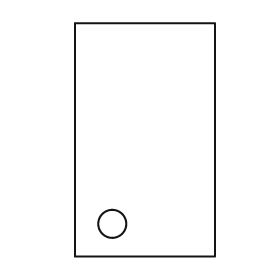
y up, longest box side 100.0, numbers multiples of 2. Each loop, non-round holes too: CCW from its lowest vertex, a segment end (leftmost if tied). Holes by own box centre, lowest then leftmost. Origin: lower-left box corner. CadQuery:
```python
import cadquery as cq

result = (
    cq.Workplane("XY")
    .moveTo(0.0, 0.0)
    .lineTo(60.0, 0.0)
    .lineTo(60.0, 100.0)
    .lineTo(0.0, 100.0)
    .close()
    .moveTo(16.0, 14.0)
    .circle(6.0)
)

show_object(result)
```